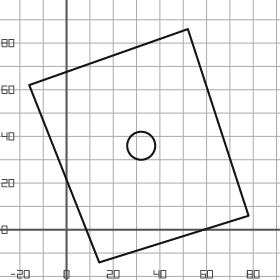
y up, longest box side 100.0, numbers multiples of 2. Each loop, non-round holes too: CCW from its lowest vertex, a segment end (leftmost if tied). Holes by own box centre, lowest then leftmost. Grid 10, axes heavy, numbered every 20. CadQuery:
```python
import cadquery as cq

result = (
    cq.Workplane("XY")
    .moveTo(14.0, -14.0)
    .lineTo(78.0, 6.0)
    .lineTo(52.0, 86.0)
    .lineTo(-16.0, 62.0)
    .close()
    .moveTo(32.0, 36.0)
    .circle(6.0)
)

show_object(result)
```